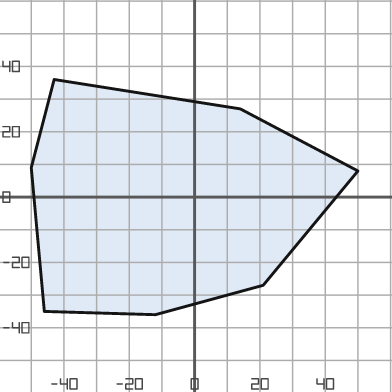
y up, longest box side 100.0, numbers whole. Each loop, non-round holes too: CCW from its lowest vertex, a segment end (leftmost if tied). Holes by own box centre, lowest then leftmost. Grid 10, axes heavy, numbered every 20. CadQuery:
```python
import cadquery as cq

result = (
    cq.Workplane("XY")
    .moveTo(-12.0, -36.0)
    .lineTo(21.0, -27.0)
    .lineTo(50.0, 8.0)
    .lineTo(14.0, 27.0)
    .lineTo(-43.0, 36.0)
    .lineTo(-50.0, 9.0)
    .lineTo(-46.0, -35.0)
    .close()
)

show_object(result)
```